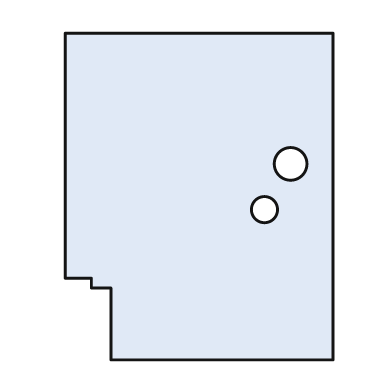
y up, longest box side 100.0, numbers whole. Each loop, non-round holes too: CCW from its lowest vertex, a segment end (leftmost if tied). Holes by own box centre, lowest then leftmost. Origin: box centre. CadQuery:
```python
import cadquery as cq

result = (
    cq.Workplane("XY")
    .moveTo(-27.0, -50.0)
    .lineTo(41.0, -50.0)
    .lineTo(41.0, 50.0)
    .lineTo(-41.0, 50.0)
    .lineTo(-41.0, -25.0)
    .lineTo(-33.0, -25.0)
    .lineTo(-33.0, -28.0)
    .lineTo(-27.0, -28.0)
    .close()
    .moveTo(20.0, -4.0)
    .circle(4.0)
    .moveTo(28.0, 10.0)
    .circle(5.0)
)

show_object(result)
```